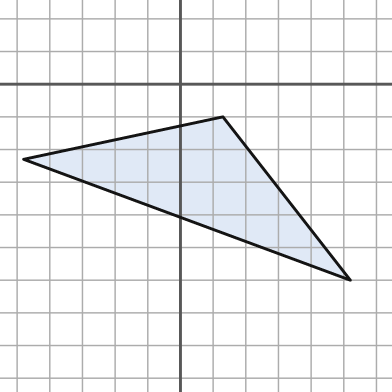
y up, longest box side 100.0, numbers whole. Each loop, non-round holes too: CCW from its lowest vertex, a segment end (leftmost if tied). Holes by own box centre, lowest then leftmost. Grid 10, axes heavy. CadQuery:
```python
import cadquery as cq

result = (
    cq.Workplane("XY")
    .moveTo(52.0, -60.0)
    .lineTo(13.0, -10.0)
    .lineTo(-48.0, -23.0)
    .close()
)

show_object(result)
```